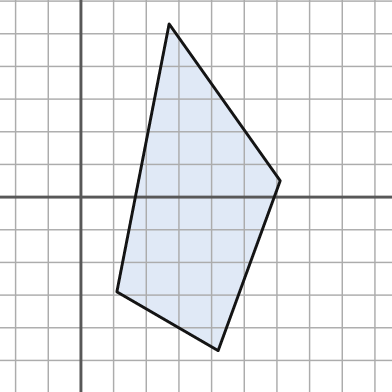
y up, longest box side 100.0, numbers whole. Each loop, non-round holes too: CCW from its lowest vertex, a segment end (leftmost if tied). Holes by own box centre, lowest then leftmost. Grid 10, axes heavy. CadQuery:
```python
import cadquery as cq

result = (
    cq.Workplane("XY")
    .moveTo(42.0, -47.0)
    .lineTo(61.0, 5.0)
    .lineTo(27.0, 53.0)
    .lineTo(11.0, -29.0)
    .close()
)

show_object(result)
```